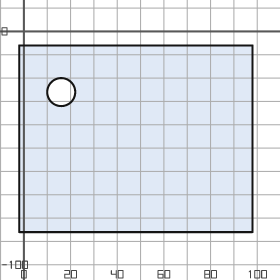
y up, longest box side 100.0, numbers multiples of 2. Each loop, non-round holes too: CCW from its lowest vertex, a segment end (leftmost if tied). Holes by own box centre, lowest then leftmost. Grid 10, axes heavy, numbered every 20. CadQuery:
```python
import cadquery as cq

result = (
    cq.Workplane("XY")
    .moveTo(-2.0, -86.0)
    .lineTo(98.0, -86.0)
    .lineTo(98.0, -6.0)
    .lineTo(-2.0, -6.0)
    .close()
    .moveTo(16.0, -26.0)
    .circle(6.0)
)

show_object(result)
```